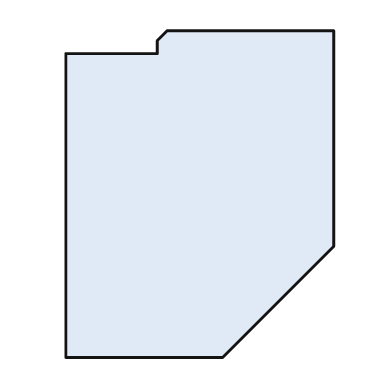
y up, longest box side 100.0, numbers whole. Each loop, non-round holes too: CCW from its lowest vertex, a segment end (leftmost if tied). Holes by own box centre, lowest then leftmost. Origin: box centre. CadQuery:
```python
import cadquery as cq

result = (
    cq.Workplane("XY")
    .moveTo(-41.0, -50.0)
    .lineTo(7.0, -50.0)
    .lineTo(41.0, -16.0)
    .lineTo(41.0, 50.0)
    .lineTo(-10.0, 50.0)
    .lineTo(-13.0, 47.0)
    .lineTo(-13.0, 43.0)
    .lineTo(-41.0, 43.0)
    .close()
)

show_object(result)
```